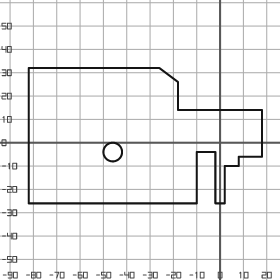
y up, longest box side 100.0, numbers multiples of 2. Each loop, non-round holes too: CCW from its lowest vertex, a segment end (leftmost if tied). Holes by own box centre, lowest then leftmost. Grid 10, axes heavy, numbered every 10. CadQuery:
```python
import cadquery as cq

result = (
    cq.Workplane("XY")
    .moveTo(-82.0, -26.0)
    .lineTo(-10.0, -26.0)
    .lineTo(-10.0, -4.0)
    .lineTo(-2.0, -4.0)
    .lineTo(-2.0, -26.0)
    .lineTo(2.0, -26.0)
    .lineTo(2.0, -10.0)
    .lineTo(8.0, -10.0)
    .lineTo(8.0, -6.0)
    .lineTo(18.0, -6.0)
    .lineTo(18.0, 14.0)
    .lineTo(-18.0, 14.0)
    .lineTo(-18.0, 26.0)
    .lineTo(-26.0, 32.0)
    .lineTo(-82.0, 32.0)
    .close()
    .moveTo(-46.0, -4.0)
    .circle(4.0)
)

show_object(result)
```